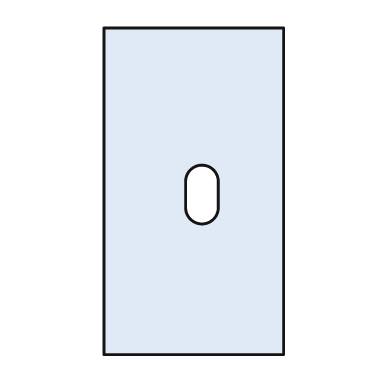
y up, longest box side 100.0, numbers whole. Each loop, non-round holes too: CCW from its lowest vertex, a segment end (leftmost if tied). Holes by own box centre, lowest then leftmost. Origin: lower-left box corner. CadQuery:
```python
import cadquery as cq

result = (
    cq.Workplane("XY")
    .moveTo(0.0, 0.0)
    .lineTo(55.0, 0.0)
    .lineTo(55.0, 100.0)
    .lineTo(0.0, 100.0)
    .close()
    .moveTo(25.0, 45.0)
    .threePointArc((30.0, 40.0), (35.0, 45.0))
    .lineTo(35.0, 53.0)
    .threePointArc((30.0, 58.0), (25.0, 53.0))
    .close()
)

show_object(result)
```